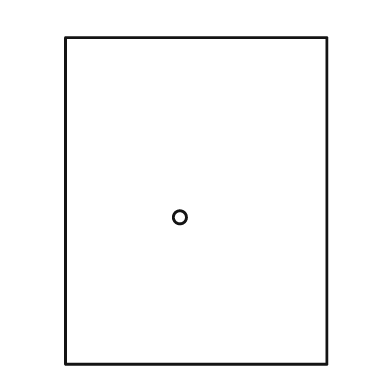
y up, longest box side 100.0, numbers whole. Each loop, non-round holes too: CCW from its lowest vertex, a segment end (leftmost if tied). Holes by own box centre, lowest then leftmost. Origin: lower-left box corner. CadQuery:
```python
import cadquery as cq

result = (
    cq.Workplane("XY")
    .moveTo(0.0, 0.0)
    .lineTo(80.0, 0.0)
    .lineTo(80.0, 100.0)
    .lineTo(0.0, 100.0)
    .close()
    .moveTo(35.0, 45.0)
    .circle(2.0)
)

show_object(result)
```